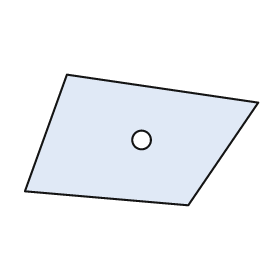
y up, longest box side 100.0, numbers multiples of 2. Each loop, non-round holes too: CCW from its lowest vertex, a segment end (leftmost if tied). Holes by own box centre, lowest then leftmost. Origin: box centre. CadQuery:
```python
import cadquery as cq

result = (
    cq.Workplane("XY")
    .moveTo(20.0, -28.0)
    .lineTo(50.0, 16.0)
    .lineTo(-32.0, 28.0)
    .lineTo(-50.0, -22.0)
    .close()
    .moveTo(0.0, 0.0)
    .circle(4.0)
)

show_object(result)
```